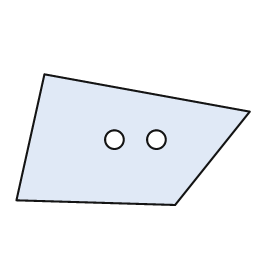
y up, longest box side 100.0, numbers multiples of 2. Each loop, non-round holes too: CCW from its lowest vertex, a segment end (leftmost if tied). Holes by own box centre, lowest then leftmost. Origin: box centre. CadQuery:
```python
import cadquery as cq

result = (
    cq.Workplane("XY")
    .moveTo(18.0, -28.0)
    .lineTo(50.0, 12.0)
    .lineTo(-38.0, 28.0)
    .lineTo(-50.0, -26.0)
    .close()
    .moveTo(-8.0, 0.0)
    .circle(4.0)
    .moveTo(10.0, 0.0)
    .circle(4.0)
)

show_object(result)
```